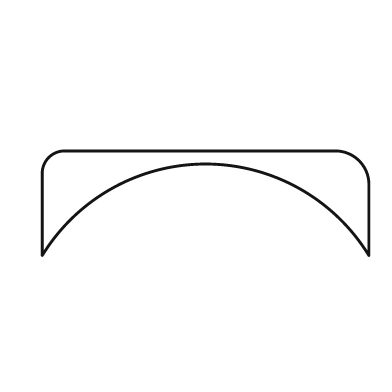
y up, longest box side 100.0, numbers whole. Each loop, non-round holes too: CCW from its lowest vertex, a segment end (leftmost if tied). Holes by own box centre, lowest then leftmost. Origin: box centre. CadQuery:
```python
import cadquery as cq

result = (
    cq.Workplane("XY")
    .moveTo(-50.0, -16.0)
    .threePointArc((0.0, 12.0), (50.0, -16.0))
    .lineTo(50.0, 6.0)
    .threePointArc((47.0, 13.0), (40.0, 16.0))
    .lineTo(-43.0, 16.0)
    .threePointArc((-48.0, 14.0), (-50.0, 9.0))
    .close()
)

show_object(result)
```